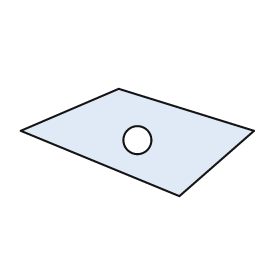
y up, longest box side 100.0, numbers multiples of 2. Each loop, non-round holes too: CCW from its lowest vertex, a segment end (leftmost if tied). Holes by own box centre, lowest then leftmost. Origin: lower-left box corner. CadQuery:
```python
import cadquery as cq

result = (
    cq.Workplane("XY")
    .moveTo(68.0, 0.0)
    .lineTo(100.0, 28.0)
    .lineTo(42.0, 46.0)
    .lineTo(0.0, 28.0)
    .close()
    .moveTo(50.0, 24.0)
    .circle(6.0)
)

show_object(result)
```